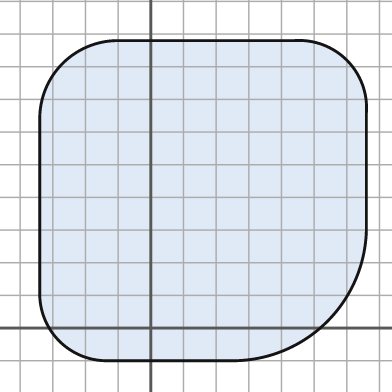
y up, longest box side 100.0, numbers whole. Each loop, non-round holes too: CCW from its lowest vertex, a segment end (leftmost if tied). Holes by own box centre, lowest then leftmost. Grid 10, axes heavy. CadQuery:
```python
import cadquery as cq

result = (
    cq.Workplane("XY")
    .moveTo(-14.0, -10.0)
    .lineTo(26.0, -10.0)
    .threePointArc((54.0, 2.0), (66.0, 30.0))
    .lineTo(66.0, 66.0)
    .threePointArc((60.0, 82.0), (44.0, 88.0))
    .lineTo(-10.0, 88.0)
    .threePointArc((-27.0, 81.0), (-34.0, 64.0))
    .lineTo(-34.0, 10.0)
    .threePointArc((-28.0, -4.0), (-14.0, -10.0))
    .close()
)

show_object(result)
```